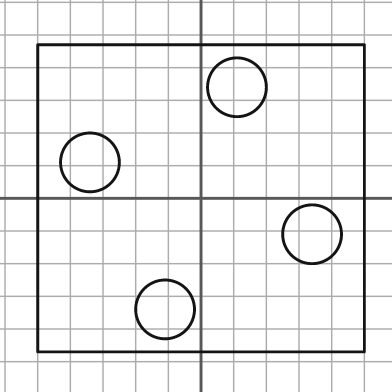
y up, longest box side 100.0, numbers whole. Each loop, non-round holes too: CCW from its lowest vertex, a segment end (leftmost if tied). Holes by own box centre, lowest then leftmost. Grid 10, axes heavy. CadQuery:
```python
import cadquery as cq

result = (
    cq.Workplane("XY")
    .moveTo(-50.0, -47.0)
    .lineTo(50.0, -47.0)
    .lineTo(50.0, 47.0)
    .lineTo(-50.0, 47.0)
    .close()
    .moveTo(-11.0, -34.0)
    .circle(9.0)
    .moveTo(34.0, -11.0)
    .circle(9.0)
    .moveTo(-34.0, 11.0)
    .circle(9.0)
    .moveTo(11.0, 34.0)
    .circle(9.0)
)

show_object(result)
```